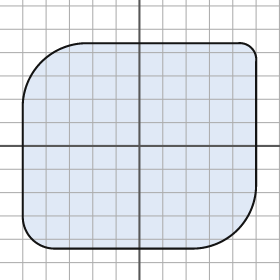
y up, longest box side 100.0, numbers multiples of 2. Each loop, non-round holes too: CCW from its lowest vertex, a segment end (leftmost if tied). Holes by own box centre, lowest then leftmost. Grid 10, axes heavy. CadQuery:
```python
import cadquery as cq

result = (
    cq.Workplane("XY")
    .moveTo(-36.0, -44.0)
    .lineTo(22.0, -44.0)
    .threePointArc((42.0, -36.0), (50.0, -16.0))
    .lineTo(50.0, 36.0)
    .threePointArc((48.0, 42.0), (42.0, 44.0))
    .lineTo(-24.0, 44.0)
    .threePointArc((-42.0, 36.0), (-50.0, 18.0))
    .lineTo(-50.0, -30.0)
    .threePointArc((-46.0, -40.0), (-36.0, -44.0))
    .close()
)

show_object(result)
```